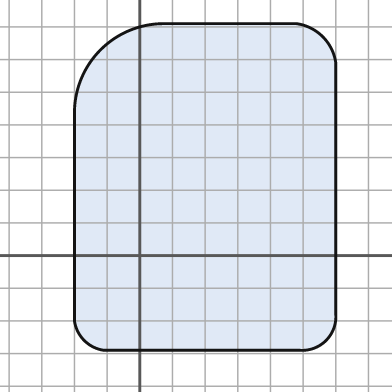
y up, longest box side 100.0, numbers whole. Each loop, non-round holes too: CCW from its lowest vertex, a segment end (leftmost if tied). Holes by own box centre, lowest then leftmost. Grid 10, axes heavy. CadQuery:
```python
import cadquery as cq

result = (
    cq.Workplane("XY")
    .moveTo(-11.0, -29.0)
    .lineTo(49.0, -29.0)
    .threePointArc((57.0, -26.0), (60.0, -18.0))
    .lineTo(60.0, 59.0)
    .threePointArc((56.0, 67.0), (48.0, 71.0))
    .lineTo(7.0, 71.0)
    .threePointArc((-12.0, 63.0), (-20.0, 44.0))
    .lineTo(-20.0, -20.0)
    .threePointArc((-17.0, -26.0), (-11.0, -29.0))
    .close()
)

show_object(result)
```